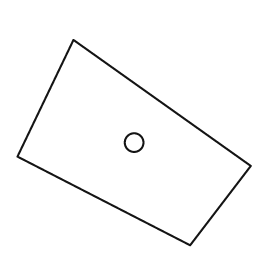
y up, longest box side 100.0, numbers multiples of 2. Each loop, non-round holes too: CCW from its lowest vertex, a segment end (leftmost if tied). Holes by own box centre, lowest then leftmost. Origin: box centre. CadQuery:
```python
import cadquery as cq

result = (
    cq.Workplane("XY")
    .moveTo(24.0, -44.0)
    .lineTo(50.0, -10.0)
    .lineTo(-26.0, 44.0)
    .lineTo(-50.0, -6.0)
    .close()
    .moveTo(0.0, 0.0)
    .circle(4.0)
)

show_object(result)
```